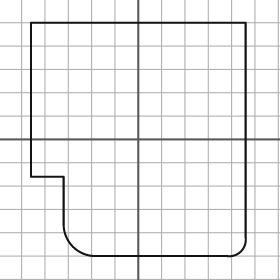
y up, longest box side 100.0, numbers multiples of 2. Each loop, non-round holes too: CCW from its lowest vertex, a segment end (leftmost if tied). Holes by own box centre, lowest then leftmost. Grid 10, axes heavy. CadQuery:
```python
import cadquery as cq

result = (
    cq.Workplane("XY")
    .moveTo(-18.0, -50.0)
    .lineTo(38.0, -50.0)
    .threePointArc((44.0, -48.0), (46.0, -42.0))
    .lineTo(46.0, 50.0)
    .lineTo(-46.0, 50.0)
    .lineTo(-46.0, -16.0)
    .lineTo(-32.0, -16.0)
    .lineTo(-32.0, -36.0)
    .threePointArc((-28.0, -46.0), (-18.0, -50.0))
    .close()
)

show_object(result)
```